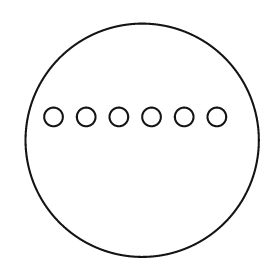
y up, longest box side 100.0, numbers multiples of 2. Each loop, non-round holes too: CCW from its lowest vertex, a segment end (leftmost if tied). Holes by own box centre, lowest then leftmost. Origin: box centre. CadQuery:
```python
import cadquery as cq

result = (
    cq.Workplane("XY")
    .moveTo(0.0, 0.0)
    .circle(50.0)
    .moveTo(-38.0, 10.0)
    .circle(4.0)
    .moveTo(-24.0, 10.0)
    .circle(4.0)
    .moveTo(-10.0, 10.0)
    .circle(4.0)
    .moveTo(4.0, 10.0)
    .circle(4.0)
    .moveTo(18.0, 10.0)
    .circle(4.0)
    .moveTo(32.0, 10.0)
    .circle(4.0)
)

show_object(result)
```